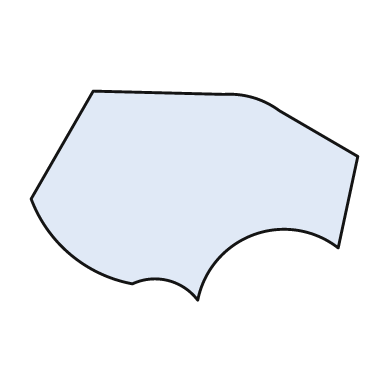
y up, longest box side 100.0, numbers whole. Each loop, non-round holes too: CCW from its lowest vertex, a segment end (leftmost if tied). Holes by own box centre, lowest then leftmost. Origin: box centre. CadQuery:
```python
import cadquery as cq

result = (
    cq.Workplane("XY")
    .moveTo(1.0, -32.0)
    .threePointArc((18.0, -12.0), (44.0, -16.0))
    .lineTo(50.0, 12.0)
    .lineTo(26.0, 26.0)
    .threePointArc((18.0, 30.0), (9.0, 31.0))
    .lineTo(-31.0, 32.0)
    .lineTo(-50.0, -1.0)
    .threePointArc((-38.0, -18.0), (-19.0, -27.0))
    .threePointArc((-8.0, -26.0), (1.0, -32.0))
    .close()
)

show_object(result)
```